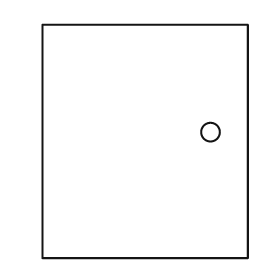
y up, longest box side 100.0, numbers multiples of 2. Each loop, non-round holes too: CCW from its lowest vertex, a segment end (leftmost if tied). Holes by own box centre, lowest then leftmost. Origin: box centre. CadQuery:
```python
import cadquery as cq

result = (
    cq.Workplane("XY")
    .moveTo(-44.0, -50.0)
    .lineTo(44.0, -50.0)
    .lineTo(44.0, 50.0)
    .lineTo(-44.0, 50.0)
    .close()
    .moveTo(28.0, 4.0)
    .circle(4.0)
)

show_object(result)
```